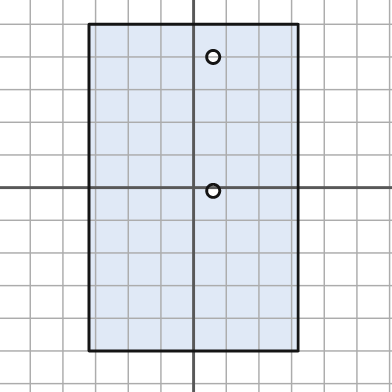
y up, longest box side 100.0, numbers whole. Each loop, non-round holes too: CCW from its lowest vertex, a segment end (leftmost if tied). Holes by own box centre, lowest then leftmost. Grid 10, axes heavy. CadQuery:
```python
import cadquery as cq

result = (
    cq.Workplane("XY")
    .moveTo(-32.0, -50.0)
    .lineTo(32.0, -50.0)
    .lineTo(32.0, 50.0)
    .lineTo(-32.0, 50.0)
    .close()
    .moveTo(6.0, -1.0)
    .circle(2.0)
    .moveTo(6.0, 40.0)
    .circle(2.0)
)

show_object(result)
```